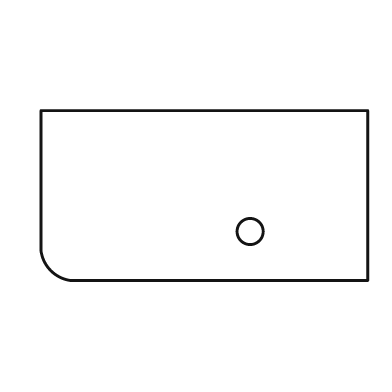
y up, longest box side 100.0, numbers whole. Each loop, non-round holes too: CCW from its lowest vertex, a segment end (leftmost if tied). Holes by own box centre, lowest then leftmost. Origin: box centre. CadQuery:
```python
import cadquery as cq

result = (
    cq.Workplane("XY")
    .moveTo(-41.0, -26.0)
    .lineTo(50.0, -26.0)
    .lineTo(50.0, 26.0)
    .lineTo(-50.0, 26.0)
    .lineTo(-50.0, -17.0)
    .threePointArc((-47.0, -23.0), (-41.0, -26.0))
    .close()
    .moveTo(14.0, -11.0)
    .circle(4.0)
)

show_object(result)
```